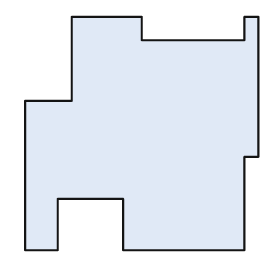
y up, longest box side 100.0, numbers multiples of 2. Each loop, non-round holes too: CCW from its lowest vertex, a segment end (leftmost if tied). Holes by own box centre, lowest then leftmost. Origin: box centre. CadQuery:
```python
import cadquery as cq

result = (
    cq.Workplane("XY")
    .moveTo(-50.0, -50.0)
    .lineTo(-36.0, -50.0)
    .lineTo(-36.0, -28.0)
    .lineTo(-8.0, -28.0)
    .lineTo(-8.0, -50.0)
    .lineTo(44.0, -50.0)
    .lineTo(44.0, -10.0)
    .lineTo(50.0, -10.0)
    .lineTo(50.0, 50.0)
    .lineTo(44.0, 50.0)
    .lineTo(44.0, 40.0)
    .lineTo(0.0, 40.0)
    .lineTo(0.0, 50.0)
    .lineTo(-30.0, 50.0)
    .lineTo(-30.0, 14.0)
    .lineTo(-50.0, 14.0)
    .close()
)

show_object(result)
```